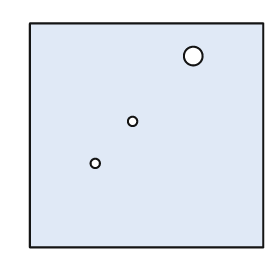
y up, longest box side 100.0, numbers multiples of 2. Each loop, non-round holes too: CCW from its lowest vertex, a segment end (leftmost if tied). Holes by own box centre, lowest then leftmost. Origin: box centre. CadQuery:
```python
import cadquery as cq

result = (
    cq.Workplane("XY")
    .moveTo(-50.0, -48.0)
    .lineTo(50.0, -48.0)
    .lineTo(50.0, 48.0)
    .lineTo(-50.0, 48.0)
    .close()
    .moveTo(-22.0, -12.0)
    .circle(2.0)
    .moveTo(-6.0, 6.0)
    .circle(2.0)
    .moveTo(20.0, 34.0)
    .circle(4.0)
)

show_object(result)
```